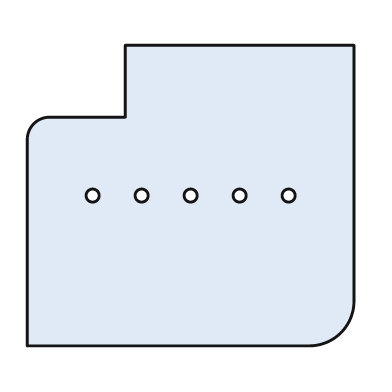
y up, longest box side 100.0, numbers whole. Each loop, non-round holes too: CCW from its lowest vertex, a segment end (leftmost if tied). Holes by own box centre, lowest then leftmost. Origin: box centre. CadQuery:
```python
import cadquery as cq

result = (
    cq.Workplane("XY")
    .moveTo(-50.0, -46.0)
    .lineTo(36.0, -46.0)
    .threePointArc((46.0, -42.0), (50.0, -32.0))
    .lineTo(50.0, 46.0)
    .lineTo(-20.0, 46.0)
    .lineTo(-20.0, 24.0)
    .lineTo(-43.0, 24.0)
    .threePointArc((-48.0, 22.0), (-50.0, 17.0))
    .close()
    .moveTo(-30.0, 0.0)
    .circle(2.0)
    .moveTo(-15.0, 0.0)
    .circle(2.0)
    .moveTo(0.0, 0.0)
    .circle(2.0)
    .moveTo(15.0, 0.0)
    .circle(2.0)
    .moveTo(30.0, 0.0)
    .circle(2.0)
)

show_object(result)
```